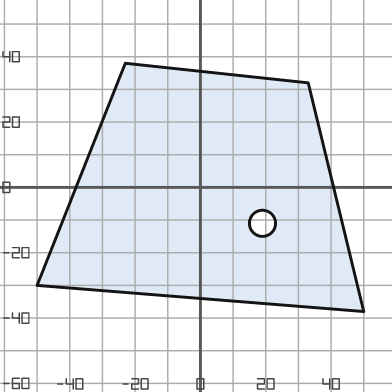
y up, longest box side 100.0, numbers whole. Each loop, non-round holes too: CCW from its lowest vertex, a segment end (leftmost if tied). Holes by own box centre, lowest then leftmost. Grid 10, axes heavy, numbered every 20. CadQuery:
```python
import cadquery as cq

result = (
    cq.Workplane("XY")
    .moveTo(50.0, -38.0)
    .lineTo(33.0, 32.0)
    .lineTo(-23.0, 38.0)
    .lineTo(-50.0, -30.0)
    .close()
    .moveTo(19.0, -11.0)
    .circle(4.0)
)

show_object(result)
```